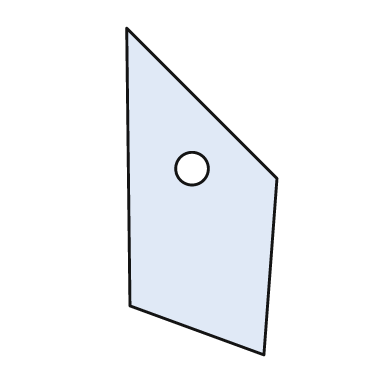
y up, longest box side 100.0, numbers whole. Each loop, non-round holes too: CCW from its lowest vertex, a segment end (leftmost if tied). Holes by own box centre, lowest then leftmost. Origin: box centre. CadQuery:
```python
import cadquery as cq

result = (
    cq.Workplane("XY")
    .moveTo(19.0, -50.0)
    .lineTo(23.0, 4.0)
    .lineTo(-23.0, 50.0)
    .lineTo(-22.0, -35.0)
    .close()
    .moveTo(-3.0, 7.0)
    .circle(5.0)
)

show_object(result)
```